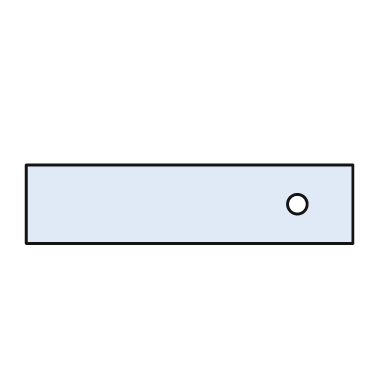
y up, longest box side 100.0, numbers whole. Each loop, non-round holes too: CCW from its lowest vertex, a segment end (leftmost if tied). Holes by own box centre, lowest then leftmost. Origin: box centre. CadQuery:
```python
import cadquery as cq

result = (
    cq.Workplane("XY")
    .moveTo(-50.0, -12.0)
    .lineTo(50.0, -12.0)
    .lineTo(50.0, 12.0)
    .lineTo(-50.0, 12.0)
    .close()
    .moveTo(33.0, 0.0)
    .circle(3.0)
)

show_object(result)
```